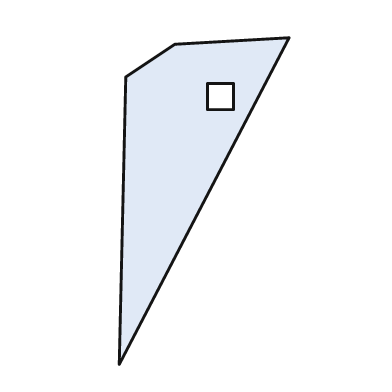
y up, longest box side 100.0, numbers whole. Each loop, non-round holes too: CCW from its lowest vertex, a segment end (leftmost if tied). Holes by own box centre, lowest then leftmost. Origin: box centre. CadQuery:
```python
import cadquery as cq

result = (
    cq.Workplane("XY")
    .moveTo(-26.0, -50.0)
    .lineTo(26.0, 50.0)
    .lineTo(-9.0, 48.0)
    .lineTo(-24.0, 38.0)
    .close()
    .moveTo(1.0, 28.0)
    .lineTo(9.0, 28.0)
    .lineTo(9.0, 36.0)
    .lineTo(1.0, 36.0)
    .close()
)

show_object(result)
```